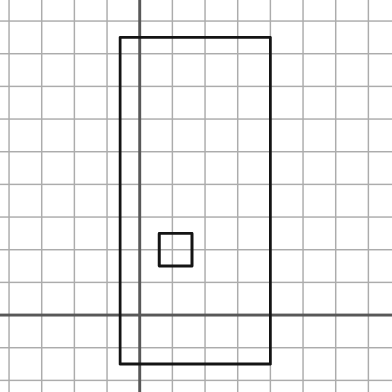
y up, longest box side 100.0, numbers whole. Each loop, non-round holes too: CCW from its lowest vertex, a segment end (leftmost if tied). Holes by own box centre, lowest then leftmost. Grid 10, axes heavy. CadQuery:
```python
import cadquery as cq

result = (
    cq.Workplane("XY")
    .moveTo(-6.0, -15.0)
    .lineTo(40.0, -15.0)
    .lineTo(40.0, 85.0)
    .lineTo(-6.0, 85.0)
    .close()
    .moveTo(6.0, 15.0)
    .lineTo(16.0, 15.0)
    .lineTo(16.0, 25.0)
    .lineTo(6.0, 25.0)
    .close()
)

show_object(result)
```